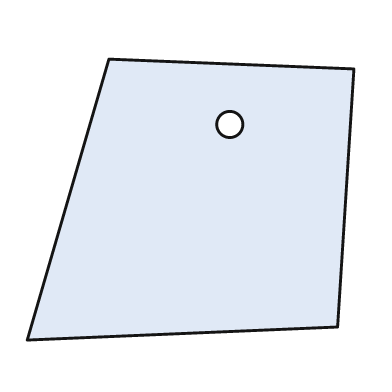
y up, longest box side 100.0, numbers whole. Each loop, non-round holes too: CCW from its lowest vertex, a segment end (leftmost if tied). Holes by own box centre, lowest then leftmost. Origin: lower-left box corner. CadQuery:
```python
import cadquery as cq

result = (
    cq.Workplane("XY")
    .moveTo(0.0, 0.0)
    .lineTo(95.0, 4.0)
    .lineTo(100.0, 83.0)
    .lineTo(25.0, 86.0)
    .close()
    .moveTo(62.0, 66.0)
    .circle(4.0)
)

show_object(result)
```